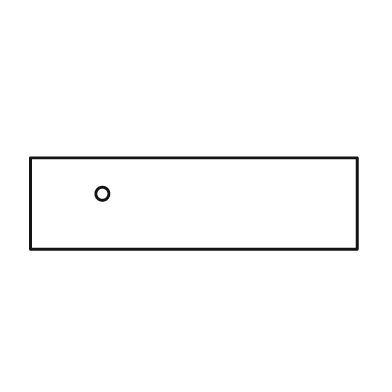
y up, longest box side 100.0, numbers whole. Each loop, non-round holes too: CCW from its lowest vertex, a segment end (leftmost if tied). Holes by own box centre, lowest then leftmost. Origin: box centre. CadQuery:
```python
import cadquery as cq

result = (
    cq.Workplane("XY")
    .moveTo(-50.0, -14.0)
    .lineTo(50.0, -14.0)
    .lineTo(50.0, 14.0)
    .lineTo(-50.0, 14.0)
    .close()
    .moveTo(-28.0, 3.0)
    .circle(2.0)
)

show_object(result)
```